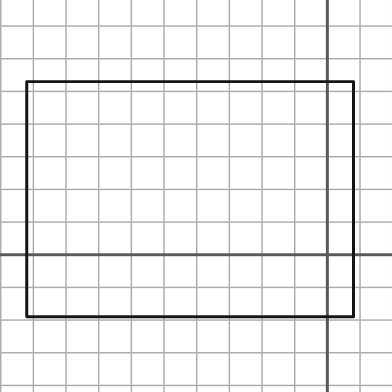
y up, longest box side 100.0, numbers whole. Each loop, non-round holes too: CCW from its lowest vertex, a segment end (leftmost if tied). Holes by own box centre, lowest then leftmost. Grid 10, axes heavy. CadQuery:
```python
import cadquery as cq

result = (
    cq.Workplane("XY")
    .moveTo(-92.0, -19.0)
    .lineTo(8.0, -19.0)
    .lineTo(8.0, 53.0)
    .lineTo(-92.0, 53.0)
    .close()
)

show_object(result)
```